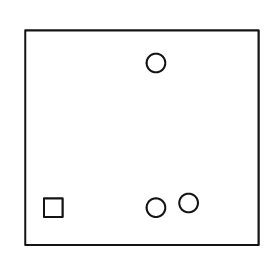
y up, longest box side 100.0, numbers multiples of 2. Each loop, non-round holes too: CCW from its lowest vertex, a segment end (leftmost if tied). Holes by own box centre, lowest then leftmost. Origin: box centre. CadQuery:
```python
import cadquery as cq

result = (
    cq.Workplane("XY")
    .moveTo(-50.0, -46.0)
    .lineTo(50.0, -46.0)
    .lineTo(50.0, 46.0)
    .lineTo(-50.0, 46.0)
    .close()
    .moveTo(-42.0, -34.0)
    .lineTo(-34.0, -34.0)
    .lineTo(-34.0, -26.0)
    .lineTo(-42.0, -26.0)
    .close()
    .moveTo(6.0, -30.0)
    .circle(4.0)
    .moveTo(20.0, -28.0)
    .circle(4.0)
    .moveTo(6.0, 32.0)
    .circle(4.0)
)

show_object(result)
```